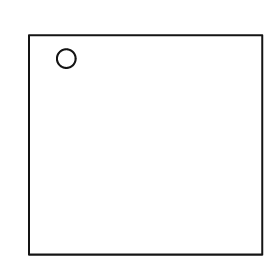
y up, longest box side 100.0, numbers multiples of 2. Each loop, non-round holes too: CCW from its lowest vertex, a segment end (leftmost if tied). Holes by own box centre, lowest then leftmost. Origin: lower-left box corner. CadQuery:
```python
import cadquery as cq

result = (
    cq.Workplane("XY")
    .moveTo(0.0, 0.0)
    .lineTo(100.0, 0.0)
    .lineTo(100.0, 94.0)
    .lineTo(0.0, 94.0)
    .close()
    .moveTo(16.0, 84.0)
    .circle(4.0)
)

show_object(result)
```